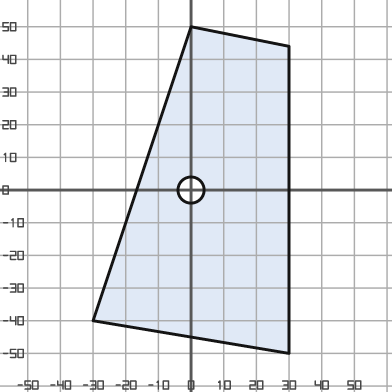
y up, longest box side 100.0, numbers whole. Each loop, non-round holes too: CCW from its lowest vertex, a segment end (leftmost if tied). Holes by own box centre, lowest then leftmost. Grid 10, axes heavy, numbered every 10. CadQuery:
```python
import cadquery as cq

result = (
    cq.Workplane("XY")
    .moveTo(30.0, -50.0)
    .lineTo(30.0, 44.0)
    .lineTo(0.0, 50.0)
    .lineTo(-30.0, -40.0)
    .close()
    .moveTo(0.0, 0.0)
    .circle(4.0)
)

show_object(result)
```